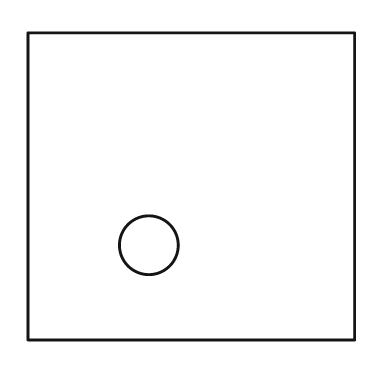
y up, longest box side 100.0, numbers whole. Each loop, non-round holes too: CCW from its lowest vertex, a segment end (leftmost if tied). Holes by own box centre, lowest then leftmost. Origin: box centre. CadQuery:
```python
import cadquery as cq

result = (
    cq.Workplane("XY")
    .moveTo(-50.0, -47.0)
    .lineTo(50.0, -47.0)
    .lineTo(50.0, 47.0)
    .lineTo(-50.0, 47.0)
    .close()
    .moveTo(-13.0, -18.0)
    .circle(9.0)
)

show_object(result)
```